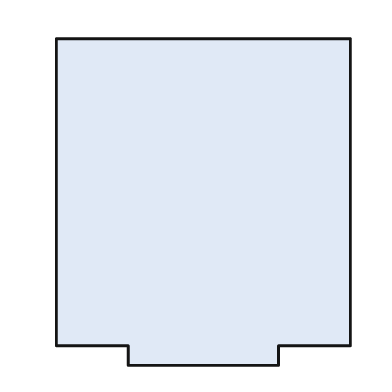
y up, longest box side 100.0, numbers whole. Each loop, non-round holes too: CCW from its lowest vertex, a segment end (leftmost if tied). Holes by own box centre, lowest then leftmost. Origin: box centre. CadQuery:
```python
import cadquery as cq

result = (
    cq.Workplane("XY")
    .moveTo(-23.0, -50.0)
    .lineTo(23.0, -50.0)
    .lineTo(23.0, -44.0)
    .lineTo(45.0, -44.0)
    .lineTo(45.0, 50.0)
    .lineTo(-45.0, 50.0)
    .lineTo(-45.0, -44.0)
    .lineTo(-23.0, -44.0)
    .close()
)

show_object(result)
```